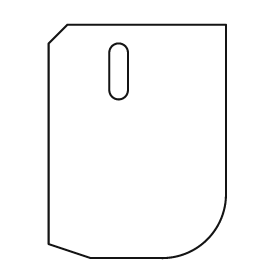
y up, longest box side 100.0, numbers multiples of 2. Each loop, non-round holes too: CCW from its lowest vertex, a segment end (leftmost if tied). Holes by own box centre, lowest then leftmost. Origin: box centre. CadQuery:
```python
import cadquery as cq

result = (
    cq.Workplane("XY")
    .moveTo(-20.0, -50.0)
    .lineTo(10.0, -50.0)
    .threePointArc((30.0, -42.0), (38.0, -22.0))
    .lineTo(38.0, 50.0)
    .lineTo(-30.0, 50.0)
    .lineTo(-38.0, 42.0)
    .lineTo(-38.0, -44.0)
    .close()
    .moveTo(-12.0, 22.0)
    .threePointArc((-8.0, 18.0), (-4.0, 22.0))
    .lineTo(-4.0, 38.0)
    .threePointArc((-8.0, 42.0), (-12.0, 38.0))
    .close()
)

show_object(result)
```